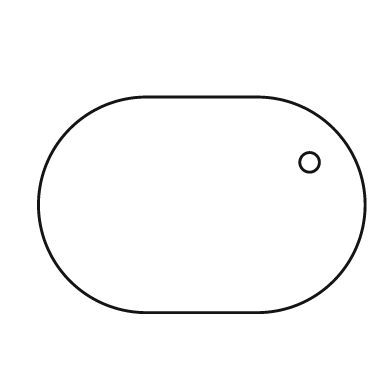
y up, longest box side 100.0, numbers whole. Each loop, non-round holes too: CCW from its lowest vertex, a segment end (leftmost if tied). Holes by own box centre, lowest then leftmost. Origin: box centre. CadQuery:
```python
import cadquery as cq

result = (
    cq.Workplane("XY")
    .moveTo(-17.0, -33.0)
    .lineTo(17.0, -33.0)
    .threePointArc((50.0, 0.0), (17.0, 33.0))
    .lineTo(-17.0, 33.0)
    .threePointArc((-50.0, 0.0), (-17.0, -33.0))
    .close()
    .moveTo(33.0, 13.0)
    .circle(3.0)
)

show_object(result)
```